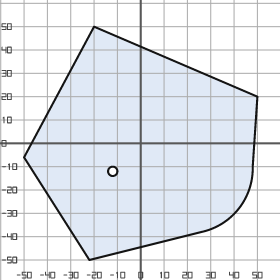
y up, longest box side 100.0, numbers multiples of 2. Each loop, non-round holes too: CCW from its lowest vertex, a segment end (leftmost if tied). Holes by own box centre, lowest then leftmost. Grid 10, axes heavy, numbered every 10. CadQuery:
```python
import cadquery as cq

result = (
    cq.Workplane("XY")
    .moveTo(-22.0, -50.0)
    .lineTo(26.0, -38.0)
    .threePointArc((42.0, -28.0), (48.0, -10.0))
    .lineTo(50.0, 20.0)
    .lineTo(-20.0, 50.0)
    .lineTo(-50.0, -6.0)
    .close()
    .moveTo(-12.0, -12.0)
    .circle(2.0)
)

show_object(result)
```